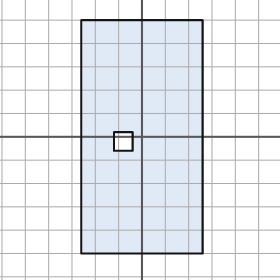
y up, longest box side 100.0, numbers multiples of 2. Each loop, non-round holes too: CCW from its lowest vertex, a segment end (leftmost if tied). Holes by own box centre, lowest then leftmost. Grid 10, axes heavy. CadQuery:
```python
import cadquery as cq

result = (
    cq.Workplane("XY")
    .moveTo(-26.0, -50.0)
    .lineTo(26.0, -50.0)
    .lineTo(26.0, 50.0)
    .lineTo(-26.0, 50.0)
    .close()
    .moveTo(-12.0, -6.0)
    .lineTo(-4.0, -6.0)
    .lineTo(-4.0, 2.0)
    .lineTo(-12.0, 2.0)
    .close()
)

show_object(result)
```